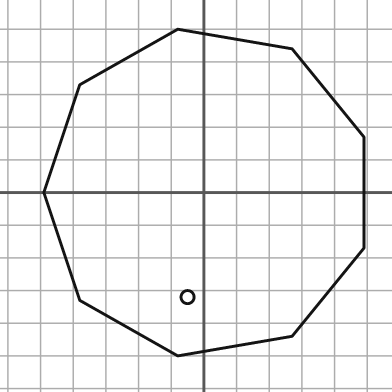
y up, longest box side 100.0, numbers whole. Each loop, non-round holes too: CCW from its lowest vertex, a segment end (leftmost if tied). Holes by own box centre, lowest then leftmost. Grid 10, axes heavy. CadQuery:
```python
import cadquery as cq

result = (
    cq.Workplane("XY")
    .moveTo(-8.0, -50.0)
    .lineTo(27.0, -44.0)
    .lineTo(49.0, -17.0)
    .lineTo(49.0, 17.0)
    .lineTo(27.0, 44.0)
    .lineTo(-8.0, 50.0)
    .lineTo(-38.0, 33.0)
    .lineTo(-49.0, 0.0)
    .lineTo(-38.0, -33.0)
    .close()
    .moveTo(-5.0, -32.0)
    .circle(2.0)
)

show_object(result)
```